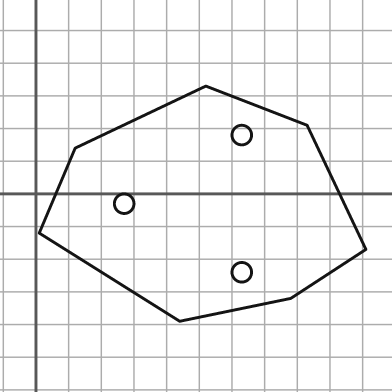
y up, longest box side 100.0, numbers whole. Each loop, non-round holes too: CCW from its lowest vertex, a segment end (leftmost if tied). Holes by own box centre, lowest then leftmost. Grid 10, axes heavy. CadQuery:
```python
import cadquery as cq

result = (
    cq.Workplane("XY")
    .moveTo(44.0, -39.0)
    .lineTo(78.0, -32.0)
    .lineTo(101.0, -17.0)
    .lineTo(83.0, 21.0)
    .lineTo(52.0, 33.0)
    .lineTo(12.0, 14.0)
    .lineTo(1.0, -12.0)
    .close()
    .moveTo(63.0, -24.0)
    .circle(3.0)
    .moveTo(27.0, -3.0)
    .circle(3.0)
    .moveTo(63.0, 18.0)
    .circle(3.0)
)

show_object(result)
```